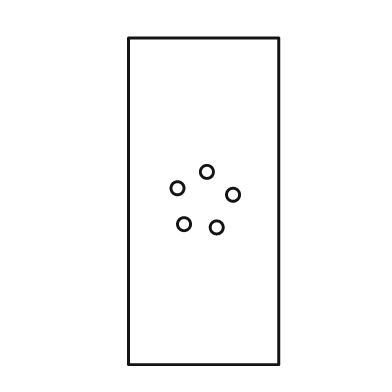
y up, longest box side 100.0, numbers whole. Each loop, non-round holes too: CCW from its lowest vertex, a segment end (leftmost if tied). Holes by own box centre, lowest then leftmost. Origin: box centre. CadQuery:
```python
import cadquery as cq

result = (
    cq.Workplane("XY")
    .moveTo(-23.0, -50.0)
    .lineTo(23.0, -50.0)
    .lineTo(23.0, 50.0)
    .lineTo(-23.0, 50.0)
    .close()
    .moveTo(4.0, -8.0)
    .circle(2.0)
    .moveTo(-6.0, -7.0)
    .circle(2.0)
    .moveTo(9.0, 2.0)
    .circle(2.0)
    .moveTo(-8.0, 4.0)
    .circle(2.0)
    .moveTo(1.0, 9.0)
    .circle(2.0)
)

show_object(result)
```